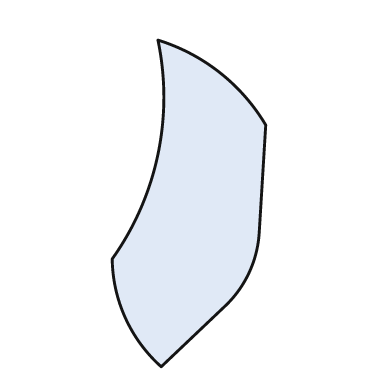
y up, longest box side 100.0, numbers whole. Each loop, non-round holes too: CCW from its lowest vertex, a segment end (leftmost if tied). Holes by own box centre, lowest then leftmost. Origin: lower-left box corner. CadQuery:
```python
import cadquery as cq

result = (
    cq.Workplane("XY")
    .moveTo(15.0, 0.0)
    .lineTo(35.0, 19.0)
    .threePointArc((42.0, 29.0), (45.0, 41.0))
    .lineTo(47.0, 74.0)
    .threePointArc((33.0, 90.0), (14.0, 100.0))
    .threePointArc((14.0, 65.0), (0.0, 33.0))
    .threePointArc((4.0, 15.0), (15.0, 0.0))
    .close()
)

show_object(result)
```